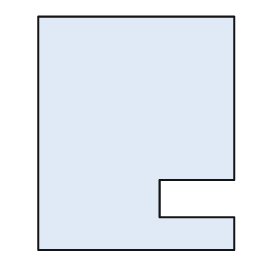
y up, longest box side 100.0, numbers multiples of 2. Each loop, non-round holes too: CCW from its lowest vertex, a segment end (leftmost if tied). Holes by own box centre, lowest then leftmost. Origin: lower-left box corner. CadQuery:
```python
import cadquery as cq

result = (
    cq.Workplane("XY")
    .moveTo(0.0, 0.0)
    .lineTo(84.0, 0.0)
    .lineTo(84.0, 14.0)
    .lineTo(52.0, 14.0)
    .lineTo(52.0, 30.0)
    .lineTo(84.0, 30.0)
    .lineTo(84.0, 100.0)
    .lineTo(0.0, 100.0)
    .close()
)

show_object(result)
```